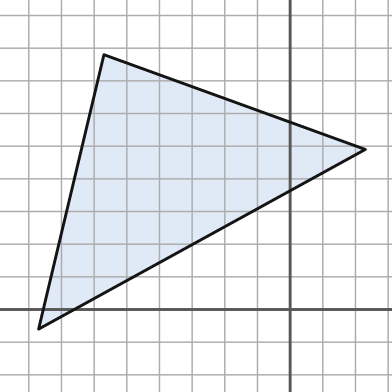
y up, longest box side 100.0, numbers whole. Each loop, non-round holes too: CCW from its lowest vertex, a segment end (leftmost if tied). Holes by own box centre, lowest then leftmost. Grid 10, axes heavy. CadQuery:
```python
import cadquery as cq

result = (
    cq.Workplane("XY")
    .moveTo(-77.0, -6.0)
    .lineTo(23.0, 49.0)
    .lineTo(-57.0, 78.0)
    .close()
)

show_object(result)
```